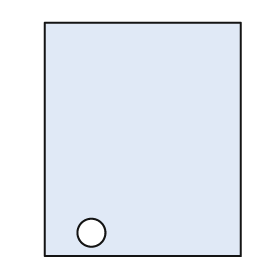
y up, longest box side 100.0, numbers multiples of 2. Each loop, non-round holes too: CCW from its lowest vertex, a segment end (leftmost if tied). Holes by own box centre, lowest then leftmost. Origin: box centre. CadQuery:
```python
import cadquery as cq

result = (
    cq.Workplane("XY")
    .moveTo(-42.0, -50.0)
    .lineTo(42.0, -50.0)
    .lineTo(42.0, 50.0)
    .lineTo(-42.0, 50.0)
    .close()
    .moveTo(-22.0, -40.0)
    .circle(6.0)
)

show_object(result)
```